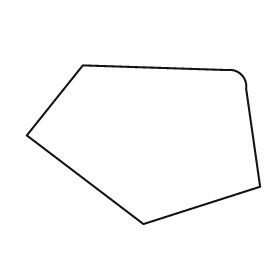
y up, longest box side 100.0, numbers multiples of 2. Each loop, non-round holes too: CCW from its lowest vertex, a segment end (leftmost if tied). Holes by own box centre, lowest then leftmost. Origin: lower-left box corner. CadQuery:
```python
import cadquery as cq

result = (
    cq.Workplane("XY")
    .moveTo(50.0, 0.0)
    .lineTo(100.0, 16.0)
    .lineTo(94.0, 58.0)
    .threePointArc((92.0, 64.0), (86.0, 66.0))
    .lineTo(24.0, 68.0)
    .lineTo(0.0, 38.0)
    .close()
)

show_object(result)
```